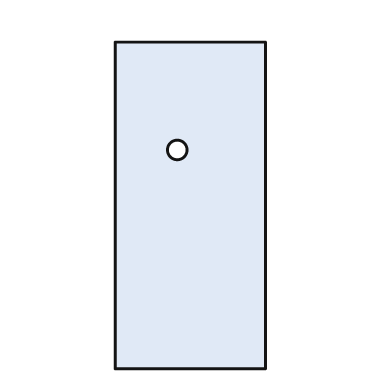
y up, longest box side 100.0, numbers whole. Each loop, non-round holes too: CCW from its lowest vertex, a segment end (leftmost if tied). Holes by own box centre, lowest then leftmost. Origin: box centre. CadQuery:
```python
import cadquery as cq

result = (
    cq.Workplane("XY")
    .moveTo(-23.0, -50.0)
    .lineTo(23.0, -50.0)
    .lineTo(23.0, 50.0)
    .lineTo(-23.0, 50.0)
    .close()
    .moveTo(-4.0, 17.0)
    .circle(3.0)
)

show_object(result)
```